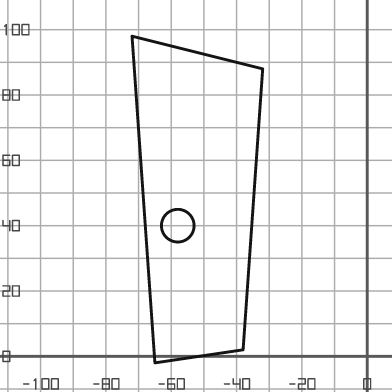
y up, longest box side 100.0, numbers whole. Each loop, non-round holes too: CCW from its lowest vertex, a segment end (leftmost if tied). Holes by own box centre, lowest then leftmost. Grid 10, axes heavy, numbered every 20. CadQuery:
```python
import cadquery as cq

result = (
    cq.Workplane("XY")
    .moveTo(-65.0, -2.0)
    .lineTo(-38.0, 2.0)
    .lineTo(-32.0, 88.0)
    .lineTo(-72.0, 98.0)
    .close()
    .moveTo(-58.0, 40.0)
    .circle(5.0)
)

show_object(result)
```